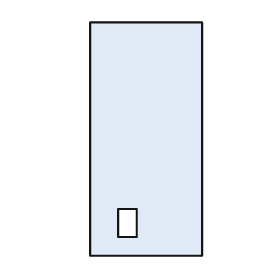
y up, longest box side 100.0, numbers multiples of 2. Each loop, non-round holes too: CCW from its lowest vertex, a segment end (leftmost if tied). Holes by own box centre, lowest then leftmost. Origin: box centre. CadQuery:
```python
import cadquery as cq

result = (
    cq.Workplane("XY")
    .moveTo(-24.0, -50.0)
    .lineTo(24.0, -50.0)
    .lineTo(24.0, 50.0)
    .lineTo(-24.0, 50.0)
    .close()
    .moveTo(-12.0, -42.0)
    .lineTo(-4.0, -42.0)
    .lineTo(-4.0, -30.0)
    .lineTo(-12.0, -30.0)
    .close()
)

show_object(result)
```